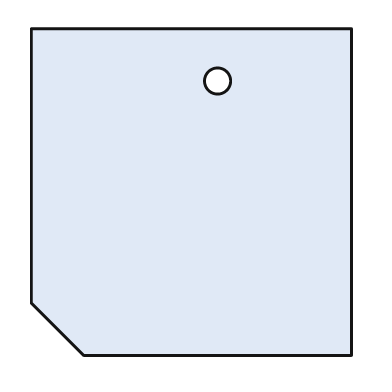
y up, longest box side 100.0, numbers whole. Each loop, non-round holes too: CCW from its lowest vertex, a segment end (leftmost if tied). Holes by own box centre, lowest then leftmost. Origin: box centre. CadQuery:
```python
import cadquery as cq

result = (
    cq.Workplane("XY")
    .moveTo(-33.0, -50.0)
    .lineTo(49.0, -50.0)
    .lineTo(49.0, 50.0)
    .lineTo(-49.0, 50.0)
    .lineTo(-49.0, -34.0)
    .close()
    .moveTo(8.0, 34.0)
    .circle(4.0)
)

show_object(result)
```